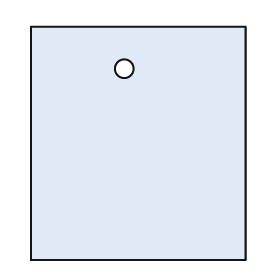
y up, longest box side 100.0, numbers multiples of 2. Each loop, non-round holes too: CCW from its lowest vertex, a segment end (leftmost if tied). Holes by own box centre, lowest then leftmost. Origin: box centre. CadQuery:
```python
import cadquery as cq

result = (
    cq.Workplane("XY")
    .moveTo(-46.0, -50.0)
    .lineTo(46.0, -50.0)
    .lineTo(46.0, 50.0)
    .lineTo(-46.0, 50.0)
    .close()
    .moveTo(-6.0, 32.0)
    .circle(4.0)
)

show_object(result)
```